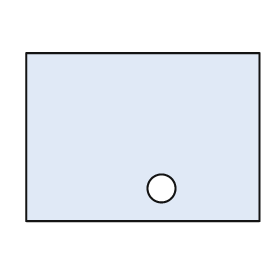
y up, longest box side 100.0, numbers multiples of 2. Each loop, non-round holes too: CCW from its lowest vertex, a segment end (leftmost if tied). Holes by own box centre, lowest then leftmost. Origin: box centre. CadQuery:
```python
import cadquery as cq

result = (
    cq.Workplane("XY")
    .moveTo(-50.0, -36.0)
    .lineTo(50.0, -36.0)
    .lineTo(50.0, 36.0)
    .lineTo(-50.0, 36.0)
    .close()
    .moveTo(8.0, -22.0)
    .circle(6.0)
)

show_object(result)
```